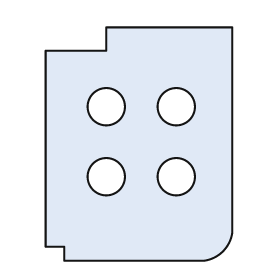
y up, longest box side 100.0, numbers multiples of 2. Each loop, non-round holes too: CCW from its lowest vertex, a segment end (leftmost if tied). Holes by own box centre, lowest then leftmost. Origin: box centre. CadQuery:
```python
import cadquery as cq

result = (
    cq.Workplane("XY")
    .moveTo(-32.0, -50.0)
    .lineTo(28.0, -50.0)
    .threePointArc((36.0, -46.0), (40.0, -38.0))
    .lineTo(40.0, 50.0)
    .lineTo(-14.0, 50.0)
    .lineTo(-14.0, 40.0)
    .lineTo(-40.0, 40.0)
    .lineTo(-40.0, -44.0)
    .lineTo(-32.0, -44.0)
    .close()
    .moveTo(-14.0, -14.0)
    .circle(8.0)
    .moveTo(16.0, -14.0)
    .circle(8.0)
    .moveTo(-14.0, 16.0)
    .circle(8.0)
    .moveTo(16.0, 16.0)
    .circle(8.0)
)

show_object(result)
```